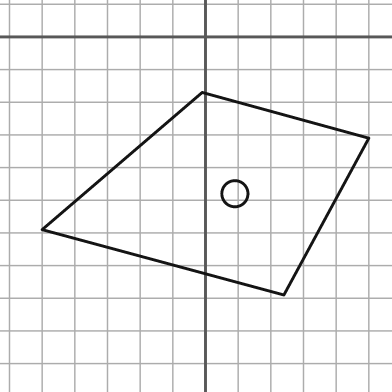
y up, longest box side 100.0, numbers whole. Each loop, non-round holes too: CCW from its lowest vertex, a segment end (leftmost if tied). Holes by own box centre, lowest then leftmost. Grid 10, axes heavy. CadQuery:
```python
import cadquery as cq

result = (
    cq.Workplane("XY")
    .moveTo(24.0, -79.0)
    .lineTo(50.0, -31.0)
    .lineTo(-1.0, -17.0)
    .lineTo(-50.0, -59.0)
    .close()
    .moveTo(9.0, -48.0)
    .circle(4.0)
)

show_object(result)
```